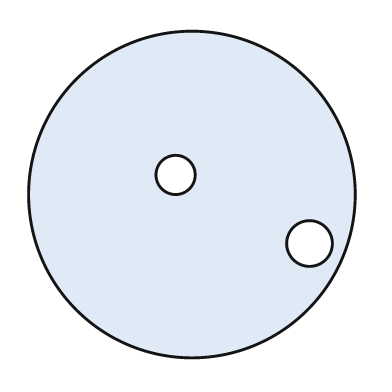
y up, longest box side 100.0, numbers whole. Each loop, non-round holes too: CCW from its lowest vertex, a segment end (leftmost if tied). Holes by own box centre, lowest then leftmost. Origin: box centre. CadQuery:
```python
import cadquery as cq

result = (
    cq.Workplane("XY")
    .moveTo(0.0, 0.0)
    .circle(50.0)
    .moveTo(36.0, -15.0)
    .circle(7.0)
    .moveTo(-5.0, 6.0)
    .circle(6.0)
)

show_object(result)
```